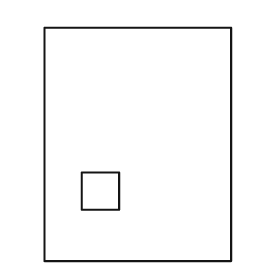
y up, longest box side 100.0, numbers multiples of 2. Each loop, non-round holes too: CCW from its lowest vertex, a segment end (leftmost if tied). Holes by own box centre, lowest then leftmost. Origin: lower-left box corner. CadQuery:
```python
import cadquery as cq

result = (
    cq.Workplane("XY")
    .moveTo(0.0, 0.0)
    .lineTo(80.0, 0.0)
    .lineTo(80.0, 100.0)
    .lineTo(0.0, 100.0)
    .close()
    .moveTo(16.0, 22.0)
    .lineTo(32.0, 22.0)
    .lineTo(32.0, 38.0)
    .lineTo(16.0, 38.0)
    .close()
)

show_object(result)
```